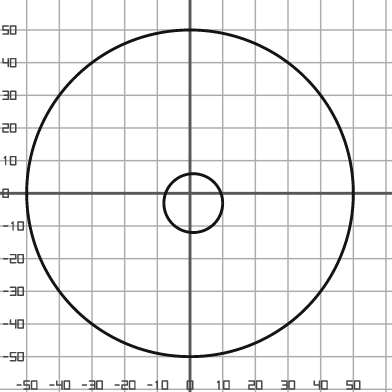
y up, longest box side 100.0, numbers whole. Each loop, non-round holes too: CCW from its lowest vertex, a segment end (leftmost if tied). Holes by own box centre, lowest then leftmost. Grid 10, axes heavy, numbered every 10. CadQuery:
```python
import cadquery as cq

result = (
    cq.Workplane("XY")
    .moveTo(0.0, 0.0)
    .circle(50.0)
    .moveTo(1.0, -3.0)
    .circle(9.0)
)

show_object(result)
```